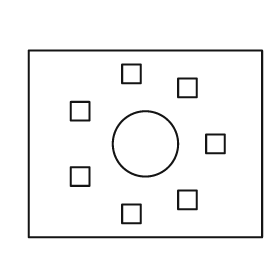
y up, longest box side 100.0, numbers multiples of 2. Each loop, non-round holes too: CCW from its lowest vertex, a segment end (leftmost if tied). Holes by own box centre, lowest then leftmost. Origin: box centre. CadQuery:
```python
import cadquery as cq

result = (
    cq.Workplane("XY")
    .moveTo(-50.0, -40.0)
    .lineTo(50.0, -40.0)
    .lineTo(50.0, 40.0)
    .lineTo(-50.0, 40.0)
    .close()
    .moveTo(-10.0, -34.0)
    .lineTo(-2.0, -34.0)
    .lineTo(-2.0, -26.0)
    .lineTo(-10.0, -26.0)
    .close()
    .moveTo(14.0, -28.0)
    .lineTo(22.0, -28.0)
    .lineTo(22.0, -20.0)
    .lineTo(14.0, -20.0)
    .close()
    .moveTo(-32.0, -18.0)
    .lineTo(-24.0, -18.0)
    .lineTo(-24.0, -10.0)
    .lineTo(-32.0, -10.0)
    .close()
    .moveTo(0.0, 0.0)
    .circle(14.0)
    .moveTo(26.0, -4.0)
    .lineTo(34.0, -4.0)
    .lineTo(34.0, 4.0)
    .lineTo(26.0, 4.0)
    .close()
    .moveTo(-32.0, 10.0)
    .lineTo(-24.0, 10.0)
    .lineTo(-24.0, 18.0)
    .lineTo(-32.0, 18.0)
    .close()
    .moveTo(14.0, 20.0)
    .lineTo(22.0, 20.0)
    .lineTo(22.0, 28.0)
    .lineTo(14.0, 28.0)
    .close()
    .moveTo(-10.0, 26.0)
    .lineTo(-2.0, 26.0)
    .lineTo(-2.0, 34.0)
    .lineTo(-10.0, 34.0)
    .close()
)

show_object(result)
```